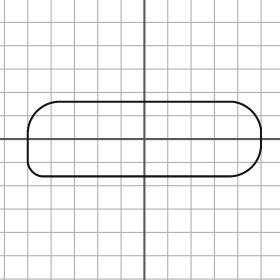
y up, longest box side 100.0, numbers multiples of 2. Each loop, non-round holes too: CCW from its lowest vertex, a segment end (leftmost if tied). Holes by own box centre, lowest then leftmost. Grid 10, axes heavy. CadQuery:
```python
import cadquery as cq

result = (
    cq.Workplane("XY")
    .moveTo(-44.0, -16.0)
    .lineTo(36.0, -16.0)
    .threePointArc((46.0, -12.0), (50.0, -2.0))
    .lineTo(50.0, 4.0)
    .threePointArc((46.0, 12.0), (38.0, 16.0))
    .lineTo(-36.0, 16.0)
    .threePointArc((-46.0, 12.0), (-50.0, 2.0))
    .lineTo(-50.0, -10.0)
    .threePointArc((-48.0, -14.0), (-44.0, -16.0))
    .close()
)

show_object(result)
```